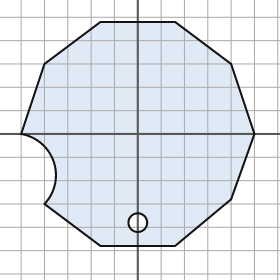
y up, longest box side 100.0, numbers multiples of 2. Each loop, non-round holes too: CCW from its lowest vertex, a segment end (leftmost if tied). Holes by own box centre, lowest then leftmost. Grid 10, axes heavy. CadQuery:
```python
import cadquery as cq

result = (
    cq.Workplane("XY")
    .moveTo(-16.0, -48.0)
    .lineTo(16.0, -48.0)
    .lineTo(40.0, -28.0)
    .lineTo(50.0, 0.0)
    .lineTo(40.0, 30.0)
    .lineTo(16.0, 48.0)
    .lineTo(-16.0, 48.0)
    .lineTo(-40.0, 30.0)
    .lineTo(-50.0, 0.0)
    .threePointArc((-36.0, -12.0), (-40.0, -30.0))
    .close()
    .moveTo(0.0, -38.0)
    .circle(4.0)
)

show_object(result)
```